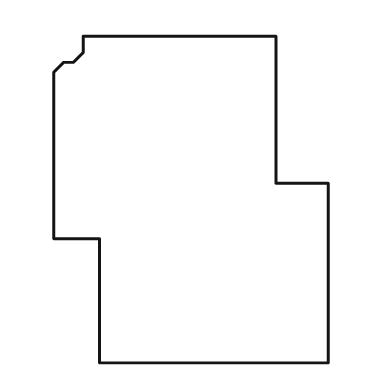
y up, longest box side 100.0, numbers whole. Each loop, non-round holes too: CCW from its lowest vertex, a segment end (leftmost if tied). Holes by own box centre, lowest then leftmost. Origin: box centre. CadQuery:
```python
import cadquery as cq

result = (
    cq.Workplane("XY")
    .moveTo(-28.0, -50.0)
    .lineTo(42.0, -50.0)
    .lineTo(42.0, 5.0)
    .lineTo(26.0, 5.0)
    .lineTo(26.0, 50.0)
    .lineTo(-33.0, 50.0)
    .lineTo(-33.0, 45.0)
    .lineTo(-36.0, 42.0)
    .lineTo(-39.0, 42.0)
    .lineTo(-42.0, 39.0)
    .lineTo(-42.0, -12.0)
    .lineTo(-28.0, -12.0)
    .close()
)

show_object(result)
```